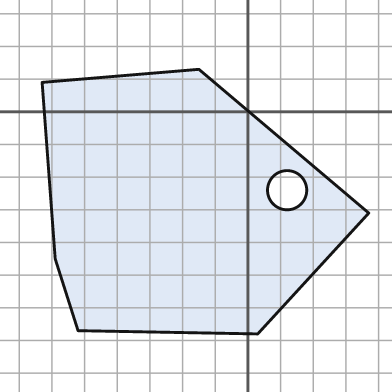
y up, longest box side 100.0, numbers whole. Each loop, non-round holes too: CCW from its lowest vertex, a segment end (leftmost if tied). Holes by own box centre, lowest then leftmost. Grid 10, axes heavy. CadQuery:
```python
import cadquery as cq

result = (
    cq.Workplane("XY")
    .moveTo(3.0, -68.0)
    .lineTo(37.0, -31.0)
    .lineTo(-15.0, 13.0)
    .lineTo(-63.0, 9.0)
    .lineTo(-59.0, -45.0)
    .lineTo(-52.0, -67.0)
    .close()
    .moveTo(12.0, -24.0)
    .circle(6.0)
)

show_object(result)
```